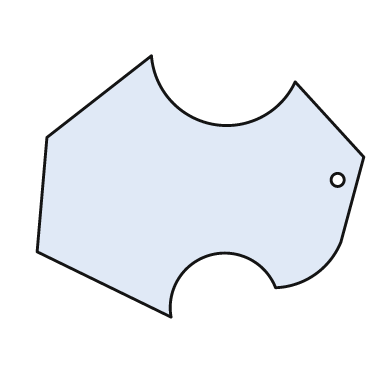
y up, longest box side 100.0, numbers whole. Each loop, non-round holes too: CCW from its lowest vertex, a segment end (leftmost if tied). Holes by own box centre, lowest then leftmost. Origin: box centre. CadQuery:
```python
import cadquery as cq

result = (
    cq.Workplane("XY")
    .moveTo(-9.0, -40.0)
    .threePointArc((3.0, -21.0), (23.0, -31.0))
    .threePointArc((35.0, -27.0), (43.0, -17.0))
    .lineTo(50.0, 9.0)
    .lineTo(29.0, 32.0)
    .threePointArc((4.0, 19.0), (-15.0, 40.0))
    .lineTo(-47.0, 15.0)
    .lineTo(-50.0, -20.0)
    .close()
    .moveTo(42.0, 2.0)
    .circle(2.0)
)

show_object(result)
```